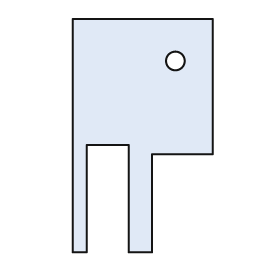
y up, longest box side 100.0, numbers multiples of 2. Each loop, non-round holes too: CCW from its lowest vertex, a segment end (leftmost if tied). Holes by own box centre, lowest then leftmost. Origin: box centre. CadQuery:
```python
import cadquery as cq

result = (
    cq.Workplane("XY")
    .moveTo(-30.0, -50.0)
    .lineTo(-24.0, -50.0)
    .lineTo(-24.0, -4.0)
    .lineTo(-6.0, -4.0)
    .lineTo(-6.0, -50.0)
    .lineTo(4.0, -50.0)
    .lineTo(4.0, -8.0)
    .lineTo(30.0, -8.0)
    .lineTo(30.0, 50.0)
    .lineTo(-30.0, 50.0)
    .close()
    .moveTo(14.0, 32.0)
    .circle(4.0)
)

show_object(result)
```